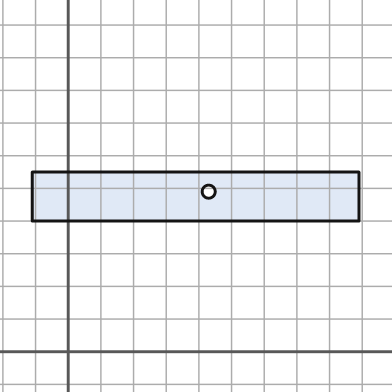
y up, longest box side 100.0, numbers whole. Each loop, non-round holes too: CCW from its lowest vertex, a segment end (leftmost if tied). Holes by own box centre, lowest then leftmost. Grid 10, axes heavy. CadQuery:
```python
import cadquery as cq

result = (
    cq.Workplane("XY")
    .moveTo(-11.0, 40.0)
    .lineTo(89.0, 40.0)
    .lineTo(89.0, 55.0)
    .lineTo(-11.0, 55.0)
    .close()
    .moveTo(43.0, 49.0)
    .circle(2.0)
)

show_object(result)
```